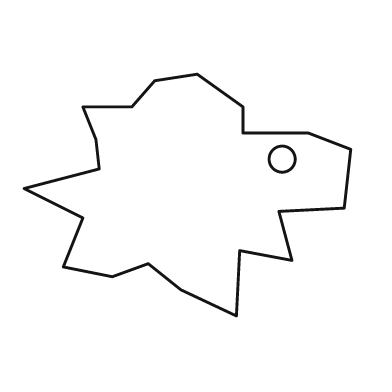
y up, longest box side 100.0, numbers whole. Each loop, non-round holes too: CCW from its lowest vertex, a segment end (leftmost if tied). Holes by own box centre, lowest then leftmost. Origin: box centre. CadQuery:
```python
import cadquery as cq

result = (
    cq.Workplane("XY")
    .moveTo(15.0, -37.0)
    .lineTo(16.0, -17.0)
    .lineTo(32.0, -20.0)
    .lineTo(28.0, -5.0)
    .lineTo(48.0, -4.0)
    .lineTo(50.0, 14.0)
    .lineTo(37.0, 19.0)
    .lineTo(17.0, 19.0)
    .lineTo(17.0, 27.0)
    .lineTo(3.0, 37.0)
    .lineTo(-10.0, 35.0)
    .lineTo(-17.0, 27.0)
    .lineTo(-32.0, 27.0)
    .lineTo(-28.0, 17.0)
    .lineTo(-27.0, 8.0)
    .lineTo(-50.0, 2.0)
    .lineTo(-32.0, -7.0)
    .lineTo(-38.0, -22.0)
    .lineTo(-23.0, -25.0)
    .lineTo(-12.0, -21.0)
    .lineTo(-2.0, -29.0)
    .close()
    .moveTo(29.0, 11.0)
    .circle(4.0)
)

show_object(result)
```